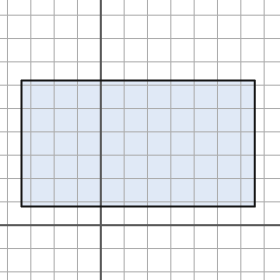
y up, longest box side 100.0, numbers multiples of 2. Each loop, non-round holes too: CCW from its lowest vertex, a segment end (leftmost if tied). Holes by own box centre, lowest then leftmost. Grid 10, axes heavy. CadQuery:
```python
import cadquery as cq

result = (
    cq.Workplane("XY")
    .moveTo(-34.0, 8.0)
    .lineTo(66.0, 8.0)
    .lineTo(66.0, 62.0)
    .lineTo(-34.0, 62.0)
    .close()
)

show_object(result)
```